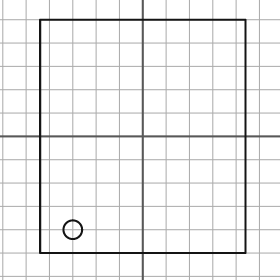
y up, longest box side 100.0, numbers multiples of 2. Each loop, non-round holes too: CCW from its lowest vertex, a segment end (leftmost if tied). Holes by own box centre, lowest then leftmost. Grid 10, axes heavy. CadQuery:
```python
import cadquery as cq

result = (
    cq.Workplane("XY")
    .moveTo(-44.0, -50.0)
    .lineTo(44.0, -50.0)
    .lineTo(44.0, 50.0)
    .lineTo(-44.0, 50.0)
    .close()
    .moveTo(-30.0, -40.0)
    .circle(4.0)
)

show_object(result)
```